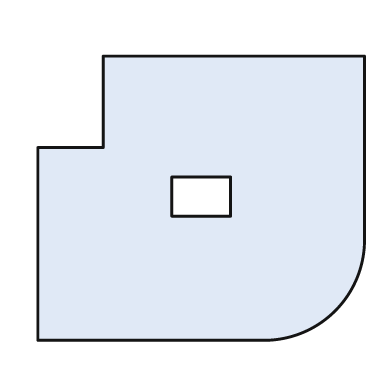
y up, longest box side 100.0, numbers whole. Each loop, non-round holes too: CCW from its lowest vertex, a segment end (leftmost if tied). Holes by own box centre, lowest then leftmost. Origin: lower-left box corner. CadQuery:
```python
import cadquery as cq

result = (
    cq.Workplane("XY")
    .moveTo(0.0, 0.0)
    .lineTo(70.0, 0.0)
    .threePointArc((91.0, 9.0), (100.0, 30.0))
    .lineTo(100.0, 87.0)
    .lineTo(20.0, 87.0)
    .lineTo(20.0, 59.0)
    .lineTo(0.0, 59.0)
    .close()
    .moveTo(41.0, 38.0)
    .lineTo(59.0, 38.0)
    .lineTo(59.0, 50.0)
    .lineTo(41.0, 50.0)
    .close()
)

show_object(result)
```